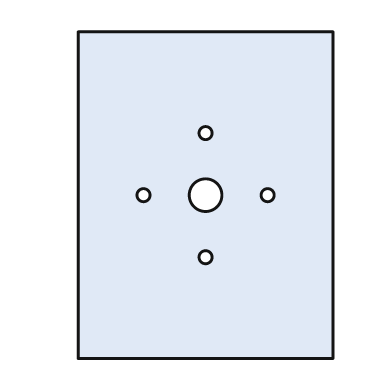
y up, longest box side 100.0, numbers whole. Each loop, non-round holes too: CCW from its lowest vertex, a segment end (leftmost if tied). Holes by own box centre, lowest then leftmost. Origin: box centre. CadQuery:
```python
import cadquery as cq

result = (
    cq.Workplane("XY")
    .moveTo(-39.0, -50.0)
    .lineTo(39.0, -50.0)
    .lineTo(39.0, 50.0)
    .lineTo(-39.0, 50.0)
    .close()
    .moveTo(0.0, -19.0)
    .circle(2.0)
    .moveTo(-19.0, 0.0)
    .circle(2.0)
    .moveTo(0.0, 0.0)
    .circle(5.0)
    .moveTo(19.0, 0.0)
    .circle(2.0)
    .moveTo(0.0, 19.0)
    .circle(2.0)
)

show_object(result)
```